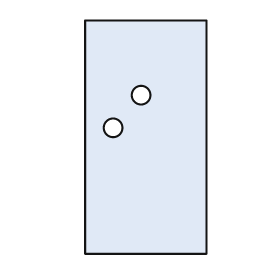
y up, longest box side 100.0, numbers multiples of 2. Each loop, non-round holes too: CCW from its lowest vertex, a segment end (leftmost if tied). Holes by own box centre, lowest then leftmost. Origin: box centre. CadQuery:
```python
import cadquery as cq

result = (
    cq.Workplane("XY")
    .moveTo(-26.0, -50.0)
    .lineTo(26.0, -50.0)
    .lineTo(26.0, 50.0)
    .lineTo(-26.0, 50.0)
    .close()
    .moveTo(-14.0, 4.0)
    .circle(4.0)
    .moveTo(-2.0, 18.0)
    .circle(4.0)
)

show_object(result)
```